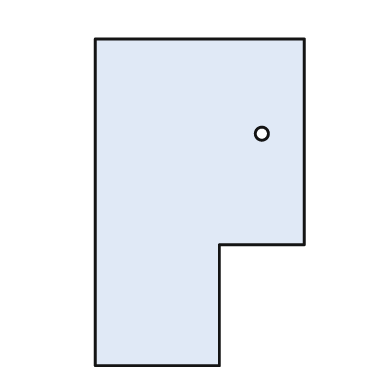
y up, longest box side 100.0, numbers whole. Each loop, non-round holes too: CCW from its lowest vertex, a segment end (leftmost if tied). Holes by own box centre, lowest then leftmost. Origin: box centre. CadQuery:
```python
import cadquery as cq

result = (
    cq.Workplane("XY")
    .moveTo(-32.0, -50.0)
    .lineTo(6.0, -50.0)
    .lineTo(6.0, -13.0)
    .lineTo(32.0, -13.0)
    .lineTo(32.0, 50.0)
    .lineTo(-32.0, 50.0)
    .close()
    .moveTo(19.0, 21.0)
    .circle(2.0)
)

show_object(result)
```